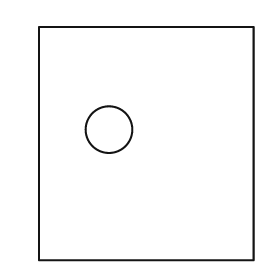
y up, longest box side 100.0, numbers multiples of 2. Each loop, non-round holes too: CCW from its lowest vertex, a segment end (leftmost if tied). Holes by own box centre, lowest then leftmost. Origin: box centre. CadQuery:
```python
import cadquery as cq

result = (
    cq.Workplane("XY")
    .moveTo(-46.0, -50.0)
    .lineTo(46.0, -50.0)
    .lineTo(46.0, 50.0)
    .lineTo(-46.0, 50.0)
    .close()
    .moveTo(-16.0, 6.0)
    .circle(10.0)
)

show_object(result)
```